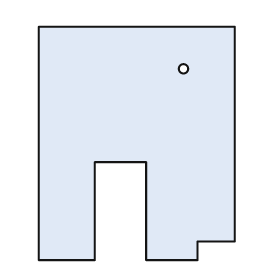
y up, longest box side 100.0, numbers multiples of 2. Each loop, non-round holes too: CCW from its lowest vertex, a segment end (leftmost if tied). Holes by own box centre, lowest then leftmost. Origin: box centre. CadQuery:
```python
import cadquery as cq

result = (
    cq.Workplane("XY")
    .moveTo(-42.0, -50.0)
    .lineTo(-18.0, -50.0)
    .lineTo(-18.0, -8.0)
    .lineTo(4.0, -8.0)
    .lineTo(4.0, -50.0)
    .lineTo(26.0, -50.0)
    .lineTo(26.0, -42.0)
    .lineTo(42.0, -42.0)
    .lineTo(42.0, 50.0)
    .lineTo(-42.0, 50.0)
    .close()
    .moveTo(20.0, 32.0)
    .circle(2.0)
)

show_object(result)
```